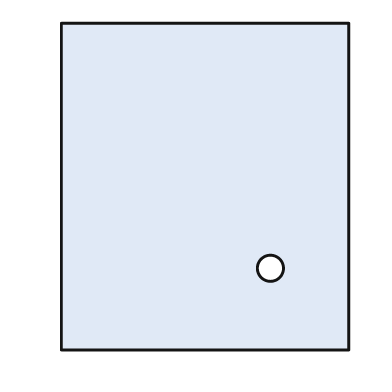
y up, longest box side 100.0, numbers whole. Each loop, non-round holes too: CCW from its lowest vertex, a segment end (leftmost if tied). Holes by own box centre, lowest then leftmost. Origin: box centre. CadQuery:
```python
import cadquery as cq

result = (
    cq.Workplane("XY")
    .moveTo(-44.0, -50.0)
    .lineTo(44.0, -50.0)
    .lineTo(44.0, 50.0)
    .lineTo(-44.0, 50.0)
    .close()
    .moveTo(20.0, -25.0)
    .circle(4.0)
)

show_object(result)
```